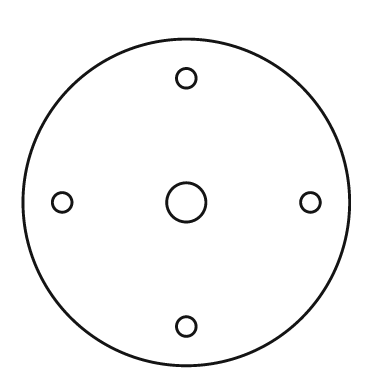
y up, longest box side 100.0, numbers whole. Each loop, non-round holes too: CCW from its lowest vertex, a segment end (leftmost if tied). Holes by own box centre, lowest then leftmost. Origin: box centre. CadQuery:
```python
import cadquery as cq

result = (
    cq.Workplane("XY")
    .moveTo(0.0, 0.0)
    .circle(50.0)
    .moveTo(0.0, -38.0)
    .circle(3.0)
    .moveTo(-38.0, 0.0)
    .circle(3.0)
    .moveTo(0.0, 0.0)
    .circle(6.0)
    .moveTo(38.0, 0.0)
    .circle(3.0)
    .moveTo(0.0, 38.0)
    .circle(3.0)
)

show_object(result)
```